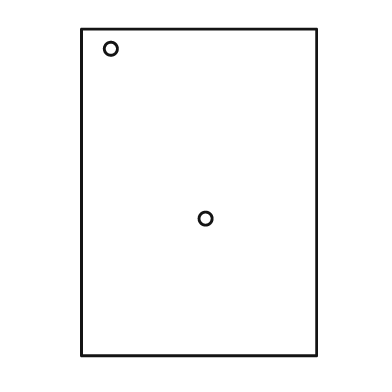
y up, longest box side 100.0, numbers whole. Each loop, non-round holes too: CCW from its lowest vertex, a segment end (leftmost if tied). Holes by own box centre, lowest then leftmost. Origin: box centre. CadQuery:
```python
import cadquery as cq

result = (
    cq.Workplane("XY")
    .moveTo(-36.0, -50.0)
    .lineTo(36.0, -50.0)
    .lineTo(36.0, 50.0)
    .lineTo(-36.0, 50.0)
    .close()
    .moveTo(2.0, -8.0)
    .circle(2.0)
    .moveTo(-27.0, 44.0)
    .circle(2.0)
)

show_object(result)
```